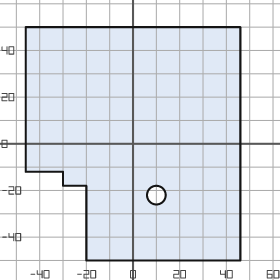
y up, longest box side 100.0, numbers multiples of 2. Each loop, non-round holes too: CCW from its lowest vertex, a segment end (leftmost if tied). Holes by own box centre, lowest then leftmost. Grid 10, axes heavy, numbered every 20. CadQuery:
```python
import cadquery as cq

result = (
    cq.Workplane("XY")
    .moveTo(-20.0, -50.0)
    .lineTo(46.0, -50.0)
    .lineTo(46.0, 50.0)
    .lineTo(-46.0, 50.0)
    .lineTo(-46.0, -12.0)
    .lineTo(-30.0, -12.0)
    .lineTo(-30.0, -18.0)
    .lineTo(-20.0, -18.0)
    .close()
    .moveTo(10.0, -22.0)
    .circle(4.0)
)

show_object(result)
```